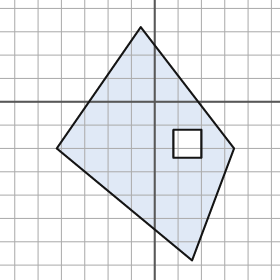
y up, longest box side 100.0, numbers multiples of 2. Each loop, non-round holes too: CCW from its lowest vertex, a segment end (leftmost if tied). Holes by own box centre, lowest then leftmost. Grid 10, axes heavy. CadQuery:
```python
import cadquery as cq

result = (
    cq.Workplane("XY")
    .moveTo(16.0, -68.0)
    .lineTo(34.0, -20.0)
    .lineTo(-6.0, 32.0)
    .lineTo(-42.0, -20.0)
    .close()
    .moveTo(8.0, -24.0)
    .lineTo(20.0, -24.0)
    .lineTo(20.0, -12.0)
    .lineTo(8.0, -12.0)
    .close()
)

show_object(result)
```